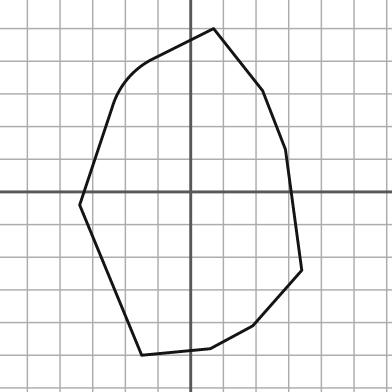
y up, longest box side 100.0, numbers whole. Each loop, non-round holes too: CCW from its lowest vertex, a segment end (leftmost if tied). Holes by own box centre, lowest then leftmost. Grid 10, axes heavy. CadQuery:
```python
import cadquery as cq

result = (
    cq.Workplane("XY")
    .moveTo(-15.0, -50.0)
    .lineTo(6.0, -48.0)
    .lineTo(19.0, -41.0)
    .lineTo(34.0, -24.0)
    .lineTo(29.0, 13.0)
    .lineTo(22.0, 31.0)
    .lineTo(7.0, 50.0)
    .lineTo(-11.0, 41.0)
    .threePointArc((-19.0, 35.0), (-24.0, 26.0))
    .lineTo(-34.0, -4.0)
    .close()
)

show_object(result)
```